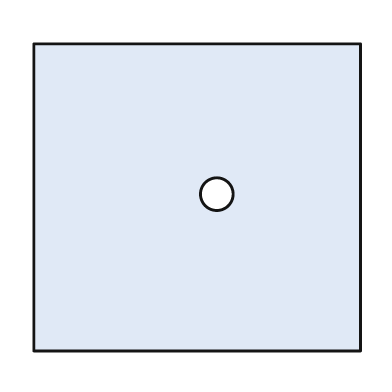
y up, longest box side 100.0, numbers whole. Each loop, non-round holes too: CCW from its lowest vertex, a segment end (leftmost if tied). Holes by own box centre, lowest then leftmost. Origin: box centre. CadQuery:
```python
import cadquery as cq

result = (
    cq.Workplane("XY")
    .moveTo(-50.0, -47.0)
    .lineTo(50.0, -47.0)
    .lineTo(50.0, 47.0)
    .lineTo(-50.0, 47.0)
    .close()
    .moveTo(6.0, 1.0)
    .circle(5.0)
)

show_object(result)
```